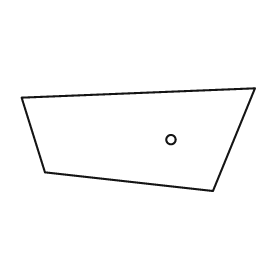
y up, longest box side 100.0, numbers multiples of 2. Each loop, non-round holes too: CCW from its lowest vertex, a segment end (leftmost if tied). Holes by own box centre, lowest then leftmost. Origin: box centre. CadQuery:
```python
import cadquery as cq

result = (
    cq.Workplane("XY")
    .moveTo(32.0, -22.0)
    .lineTo(50.0, 22.0)
    .lineTo(-50.0, 18.0)
    .lineTo(-40.0, -14.0)
    .close()
    .moveTo(14.0, 0.0)
    .circle(2.0)
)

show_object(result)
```